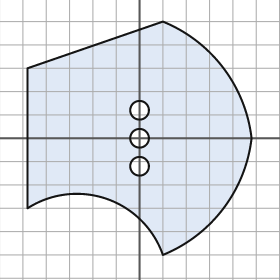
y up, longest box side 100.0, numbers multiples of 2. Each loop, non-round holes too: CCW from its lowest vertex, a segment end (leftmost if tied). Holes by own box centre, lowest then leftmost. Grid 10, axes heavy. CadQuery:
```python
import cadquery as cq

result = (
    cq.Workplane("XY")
    .moveTo(10.0, -50.0)
    .threePointArc((36.0, -30.0), (48.0, 0.0))
    .threePointArc((36.0, 30.0), (10.0, 50.0))
    .lineTo(-48.0, 30.0)
    .lineTo(-48.0, -30.0)
    .threePointArc((-14.0, -26.0), (10.0, -50.0))
    .close()
    .moveTo(0.0, -12.0)
    .circle(4.0)
    .moveTo(0.0, 0.0)
    .circle(4.0)
    .moveTo(0.0, 12.0)
    .circle(4.0)
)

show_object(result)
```